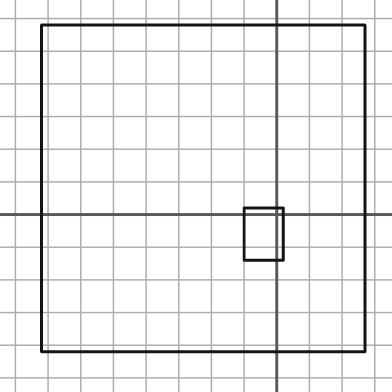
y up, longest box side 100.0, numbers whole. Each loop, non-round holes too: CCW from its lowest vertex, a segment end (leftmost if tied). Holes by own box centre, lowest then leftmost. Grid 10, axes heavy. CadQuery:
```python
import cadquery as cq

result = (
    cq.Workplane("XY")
    .moveTo(-72.0, -42.0)
    .lineTo(27.0, -42.0)
    .lineTo(27.0, 58.0)
    .lineTo(-72.0, 58.0)
    .close()
    .moveTo(-10.0, -14.0)
    .lineTo(2.0, -14.0)
    .lineTo(2.0, 2.0)
    .lineTo(-10.0, 2.0)
    .close()
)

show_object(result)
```